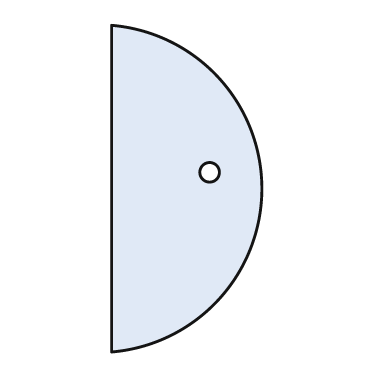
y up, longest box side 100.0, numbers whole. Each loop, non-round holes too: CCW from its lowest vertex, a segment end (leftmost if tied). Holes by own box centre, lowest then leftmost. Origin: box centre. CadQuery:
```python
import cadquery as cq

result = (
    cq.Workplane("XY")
    .moveTo(-23.0, -50.0)
    .threePointArc((23.0, 0.0), (-23.0, 50.0))
    .close()
    .moveTo(7.0, 5.0)
    .circle(3.0)
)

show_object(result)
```